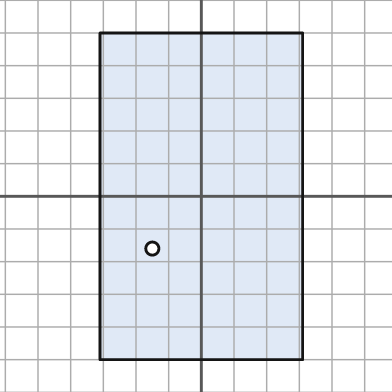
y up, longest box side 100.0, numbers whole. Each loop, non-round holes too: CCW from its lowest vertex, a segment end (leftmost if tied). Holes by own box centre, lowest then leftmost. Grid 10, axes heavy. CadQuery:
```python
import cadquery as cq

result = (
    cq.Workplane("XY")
    .moveTo(-31.0, -50.0)
    .lineTo(31.0, -50.0)
    .lineTo(31.0, 50.0)
    .lineTo(-31.0, 50.0)
    .close()
    .moveTo(-15.0, -16.0)
    .circle(2.0)
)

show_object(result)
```